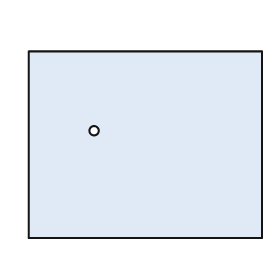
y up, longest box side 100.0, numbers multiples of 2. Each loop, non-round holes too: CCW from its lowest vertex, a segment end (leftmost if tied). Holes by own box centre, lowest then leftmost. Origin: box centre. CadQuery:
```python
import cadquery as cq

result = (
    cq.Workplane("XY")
    .moveTo(-50.0, -40.0)
    .lineTo(50.0, -40.0)
    .lineTo(50.0, 40.0)
    .lineTo(-50.0, 40.0)
    .close()
    .moveTo(-22.0, 6.0)
    .circle(2.0)
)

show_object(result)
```